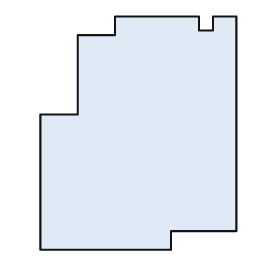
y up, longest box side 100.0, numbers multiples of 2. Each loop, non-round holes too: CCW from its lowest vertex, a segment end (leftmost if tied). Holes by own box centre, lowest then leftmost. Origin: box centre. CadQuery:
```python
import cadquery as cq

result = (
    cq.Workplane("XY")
    .moveTo(-42.0, -50.0)
    .lineTo(14.0, -50.0)
    .lineTo(14.0, -42.0)
    .lineTo(42.0, -42.0)
    .lineTo(42.0, 50.0)
    .lineTo(32.0, 50.0)
    .lineTo(32.0, 44.0)
    .lineTo(26.0, 44.0)
    .lineTo(26.0, 50.0)
    .lineTo(-10.0, 50.0)
    .lineTo(-10.0, 42.0)
    .lineTo(-26.0, 42.0)
    .lineTo(-26.0, 8.0)
    .lineTo(-42.0, 8.0)
    .close()
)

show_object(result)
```